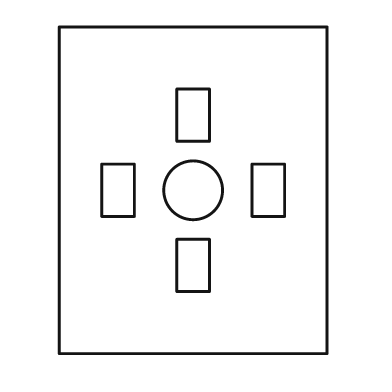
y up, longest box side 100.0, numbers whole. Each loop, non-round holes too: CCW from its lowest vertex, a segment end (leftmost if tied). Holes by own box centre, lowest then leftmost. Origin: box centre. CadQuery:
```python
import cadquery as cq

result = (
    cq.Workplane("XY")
    .moveTo(-41.0, -50.0)
    .lineTo(41.0, -50.0)
    .lineTo(41.0, 50.0)
    .lineTo(-41.0, 50.0)
    .close()
    .moveTo(-5.0, -31.0)
    .lineTo(5.0, -31.0)
    .lineTo(5.0, -15.0)
    .lineTo(-5.0, -15.0)
    .close()
    .moveTo(-28.0, -8.0)
    .lineTo(-18.0, -8.0)
    .lineTo(-18.0, 8.0)
    .lineTo(-28.0, 8.0)
    .close()
    .moveTo(0.0, 0.0)
    .circle(9.0)
    .moveTo(18.0, -8.0)
    .lineTo(28.0, -8.0)
    .lineTo(28.0, 8.0)
    .lineTo(18.0, 8.0)
    .close()
    .moveTo(-5.0, 15.0)
    .lineTo(5.0, 15.0)
    .lineTo(5.0, 31.0)
    .lineTo(-5.0, 31.0)
    .close()
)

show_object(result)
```